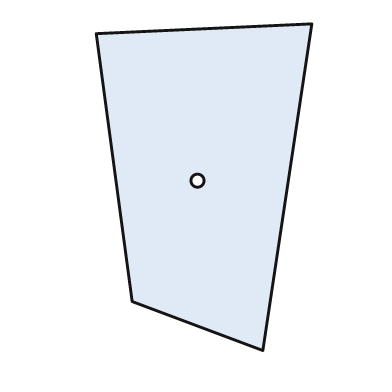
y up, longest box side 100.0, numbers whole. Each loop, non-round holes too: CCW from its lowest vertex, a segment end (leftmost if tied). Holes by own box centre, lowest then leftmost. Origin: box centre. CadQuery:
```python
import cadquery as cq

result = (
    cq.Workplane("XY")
    .moveTo(18.0, -50.0)
    .lineTo(33.0, 50.0)
    .lineTo(-33.0, 47.0)
    .lineTo(-22.0, -35.0)
    .close()
    .moveTo(-2.0, 2.0)
    .circle(2.0)
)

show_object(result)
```